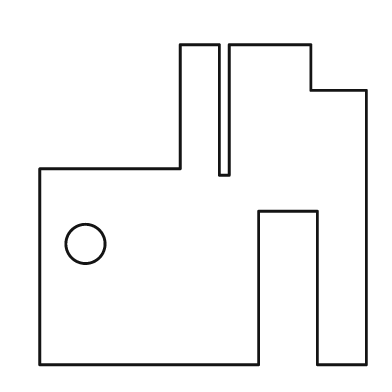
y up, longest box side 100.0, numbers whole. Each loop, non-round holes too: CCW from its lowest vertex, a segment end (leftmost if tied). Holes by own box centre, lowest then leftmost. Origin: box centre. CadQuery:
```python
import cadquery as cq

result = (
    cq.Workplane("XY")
    .moveTo(-50.0, -49.0)
    .lineTo(17.0, -49.0)
    .lineTo(17.0, -2.0)
    .lineTo(35.0, -2.0)
    .lineTo(35.0, -49.0)
    .lineTo(50.0, -49.0)
    .lineTo(50.0, 35.0)
    .lineTo(33.0, 35.0)
    .lineTo(33.0, 49.0)
    .lineTo(8.0, 49.0)
    .lineTo(8.0, 9.0)
    .lineTo(5.0, 9.0)
    .lineTo(5.0, 49.0)
    .lineTo(-7.0, 49.0)
    .lineTo(-7.0, 11.0)
    .lineTo(-50.0, 11.0)
    .close()
    .moveTo(-36.0, -12.0)
    .circle(6.0)
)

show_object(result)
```